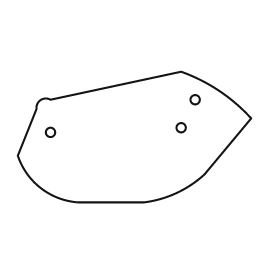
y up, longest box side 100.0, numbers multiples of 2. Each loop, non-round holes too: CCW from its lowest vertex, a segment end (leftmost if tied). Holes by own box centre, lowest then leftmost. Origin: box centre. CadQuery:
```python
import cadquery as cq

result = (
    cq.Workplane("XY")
    .moveTo(-24.0, -28.0)
    .lineTo(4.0, -28.0)
    .threePointArc((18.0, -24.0), (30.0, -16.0))
    .lineTo(50.0, 8.0)
    .threePointArc((36.0, 20.0), (20.0, 28.0))
    .lineTo(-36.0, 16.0)
    .threePointArc((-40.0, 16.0), (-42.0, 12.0))
    .lineTo(-50.0, -8.0)
    .threePointArc((-40.0, -22.0), (-24.0, -28.0))
    .close()
    .moveTo(-36.0, 2.0)
    .circle(2.0)
    .moveTo(20.0, 4.0)
    .circle(2.0)
    .moveTo(26.0, 16.0)
    .circle(2.0)
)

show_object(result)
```